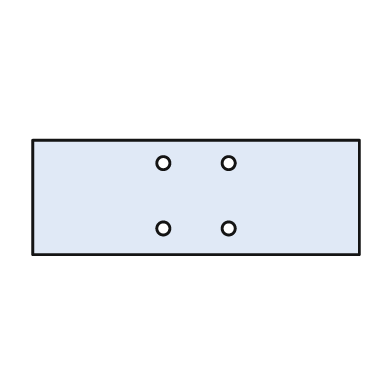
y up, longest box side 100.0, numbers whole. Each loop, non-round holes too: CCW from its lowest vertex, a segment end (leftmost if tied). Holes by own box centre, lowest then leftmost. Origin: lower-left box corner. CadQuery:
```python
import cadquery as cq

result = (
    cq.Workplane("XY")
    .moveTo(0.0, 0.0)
    .lineTo(100.0, 0.0)
    .lineTo(100.0, 35.0)
    .lineTo(0.0, 35.0)
    .close()
    .moveTo(40.0, 8.0)
    .circle(2.0)
    .moveTo(60.0, 8.0)
    .circle(2.0)
    .moveTo(40.0, 28.0)
    .circle(2.0)
    .moveTo(60.0, 28.0)
    .circle(2.0)
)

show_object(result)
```